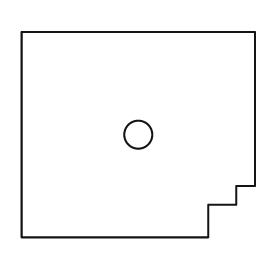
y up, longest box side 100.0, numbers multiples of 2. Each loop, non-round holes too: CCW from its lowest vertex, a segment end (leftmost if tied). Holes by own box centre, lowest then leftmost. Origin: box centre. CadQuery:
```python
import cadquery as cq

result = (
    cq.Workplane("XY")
    .moveTo(-50.0, -44.0)
    .lineTo(30.0, -44.0)
    .lineTo(30.0, -30.0)
    .lineTo(42.0, -30.0)
    .lineTo(42.0, -22.0)
    .lineTo(50.0, -22.0)
    .lineTo(50.0, 44.0)
    .lineTo(-50.0, 44.0)
    .close()
    .moveTo(0.0, 0.0)
    .circle(6.0)
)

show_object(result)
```